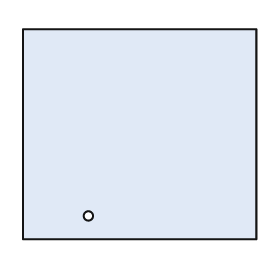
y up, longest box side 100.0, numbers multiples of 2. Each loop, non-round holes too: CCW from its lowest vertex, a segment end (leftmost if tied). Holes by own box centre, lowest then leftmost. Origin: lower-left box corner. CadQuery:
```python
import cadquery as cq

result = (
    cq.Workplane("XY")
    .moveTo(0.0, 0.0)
    .lineTo(100.0, 0.0)
    .lineTo(100.0, 90.0)
    .lineTo(0.0, 90.0)
    .close()
    .moveTo(28.0, 10.0)
    .circle(2.0)
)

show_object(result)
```